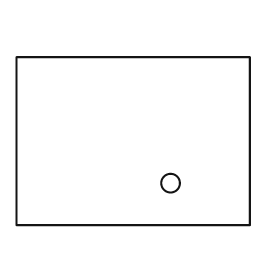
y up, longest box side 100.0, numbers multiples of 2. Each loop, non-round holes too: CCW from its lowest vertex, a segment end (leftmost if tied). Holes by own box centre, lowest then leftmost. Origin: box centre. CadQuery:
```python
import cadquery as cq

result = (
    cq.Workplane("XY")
    .moveTo(-50.0, -36.0)
    .lineTo(50.0, -36.0)
    .lineTo(50.0, 36.0)
    .lineTo(-50.0, 36.0)
    .close()
    .moveTo(16.0, -18.0)
    .circle(4.0)
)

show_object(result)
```